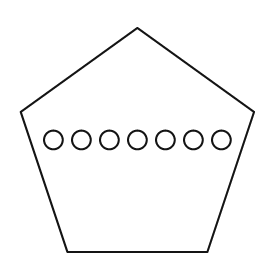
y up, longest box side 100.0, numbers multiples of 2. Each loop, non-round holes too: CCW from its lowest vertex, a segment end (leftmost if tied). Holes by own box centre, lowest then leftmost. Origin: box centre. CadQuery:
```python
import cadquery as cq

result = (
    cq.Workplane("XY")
    .moveTo(-30.0, -48.0)
    .lineTo(30.0, -48.0)
    .lineTo(50.0, 12.0)
    .lineTo(0.0, 48.0)
    .lineTo(-50.0, 12.0)
    .close()
    .moveTo(-36.0, 0.0)
    .circle(4.0)
    .moveTo(-24.0, 0.0)
    .circle(4.0)
    .moveTo(-12.0, 0.0)
    .circle(4.0)
    .moveTo(0.0, 0.0)
    .circle(4.0)
    .moveTo(12.0, 0.0)
    .circle(4.0)
    .moveTo(24.0, 0.0)
    .circle(4.0)
    .moveTo(36.0, 0.0)
    .circle(4.0)
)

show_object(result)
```